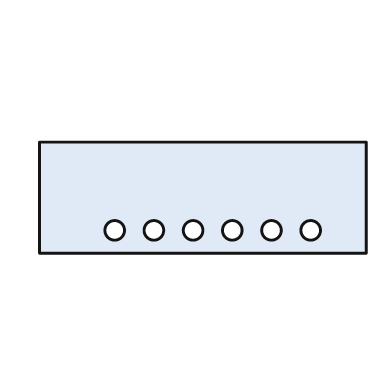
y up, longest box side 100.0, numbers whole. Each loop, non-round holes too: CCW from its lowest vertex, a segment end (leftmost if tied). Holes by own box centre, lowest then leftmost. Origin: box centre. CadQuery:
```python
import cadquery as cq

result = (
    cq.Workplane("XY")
    .moveTo(-50.0, -17.0)
    .lineTo(50.0, -17.0)
    .lineTo(50.0, 17.0)
    .lineTo(-50.0, 17.0)
    .close()
    .moveTo(-27.0, -10.0)
    .circle(3.0)
    .moveTo(-15.0, -10.0)
    .circle(3.0)
    .moveTo(-3.0, -10.0)
    .circle(3.0)
    .moveTo(9.0, -10.0)
    .circle(3.0)
    .moveTo(21.0, -10.0)
    .circle(3.0)
    .moveTo(33.0, -10.0)
    .circle(3.0)
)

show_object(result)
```